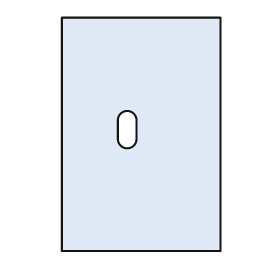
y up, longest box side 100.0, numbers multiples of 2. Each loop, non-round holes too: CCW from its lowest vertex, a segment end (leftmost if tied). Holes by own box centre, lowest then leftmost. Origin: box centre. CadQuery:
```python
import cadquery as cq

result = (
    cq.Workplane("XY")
    .moveTo(-34.0, -50.0)
    .lineTo(34.0, -50.0)
    .lineTo(34.0, 50.0)
    .lineTo(-34.0, 50.0)
    .close()
    .moveTo(-10.0, -2.0)
    .threePointArc((-6.0, -6.0), (-2.0, -2.0))
    .lineTo(-2.0, 6.0)
    .threePointArc((-6.0, 10.0), (-10.0, 6.0))
    .close()
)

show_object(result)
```